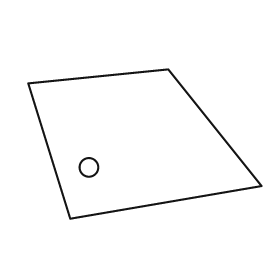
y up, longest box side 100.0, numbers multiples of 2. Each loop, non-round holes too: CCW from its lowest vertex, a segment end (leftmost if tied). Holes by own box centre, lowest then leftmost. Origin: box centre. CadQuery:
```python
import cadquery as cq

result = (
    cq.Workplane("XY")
    .moveTo(-32.0, -32.0)
    .lineTo(50.0, -18.0)
    .lineTo(10.0, 32.0)
    .lineTo(-50.0, 26.0)
    .close()
    .moveTo(-24.0, -10.0)
    .circle(4.0)
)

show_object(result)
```